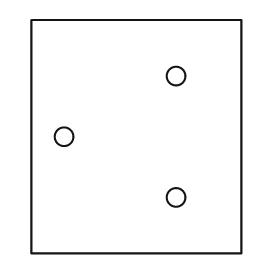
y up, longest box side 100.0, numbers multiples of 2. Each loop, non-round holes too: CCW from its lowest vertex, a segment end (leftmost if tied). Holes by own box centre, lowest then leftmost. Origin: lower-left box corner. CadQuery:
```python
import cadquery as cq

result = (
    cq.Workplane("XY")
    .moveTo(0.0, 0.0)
    .lineTo(90.0, 0.0)
    .lineTo(90.0, 100.0)
    .lineTo(0.0, 100.0)
    .close()
    .moveTo(62.0, 24.0)
    .circle(4.0)
    .moveTo(14.0, 50.0)
    .circle(4.0)
    .moveTo(62.0, 76.0)
    .circle(4.0)
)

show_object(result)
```